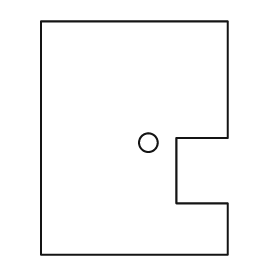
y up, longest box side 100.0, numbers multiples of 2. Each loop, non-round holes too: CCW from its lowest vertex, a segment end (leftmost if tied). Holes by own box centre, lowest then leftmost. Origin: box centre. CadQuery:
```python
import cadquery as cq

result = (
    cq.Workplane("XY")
    .moveTo(-40.0, -50.0)
    .lineTo(40.0, -50.0)
    .lineTo(40.0, -28.0)
    .lineTo(18.0, -28.0)
    .lineTo(18.0, 0.0)
    .lineTo(40.0, 0.0)
    .lineTo(40.0, 50.0)
    .lineTo(-40.0, 50.0)
    .close()
    .moveTo(6.0, -2.0)
    .circle(4.0)
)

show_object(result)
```